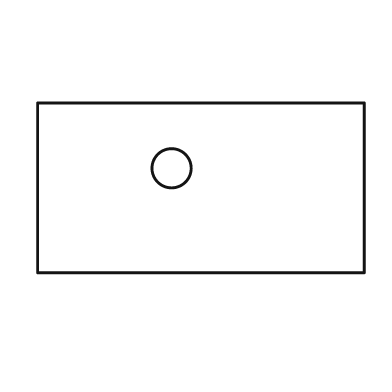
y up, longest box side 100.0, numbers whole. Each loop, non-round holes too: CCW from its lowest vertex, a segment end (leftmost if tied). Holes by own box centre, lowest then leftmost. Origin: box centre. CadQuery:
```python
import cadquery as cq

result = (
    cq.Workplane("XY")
    .moveTo(-50.0, -26.0)
    .lineTo(50.0, -26.0)
    .lineTo(50.0, 26.0)
    .lineTo(-50.0, 26.0)
    .close()
    .moveTo(-9.0, 6.0)
    .circle(6.0)
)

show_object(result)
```